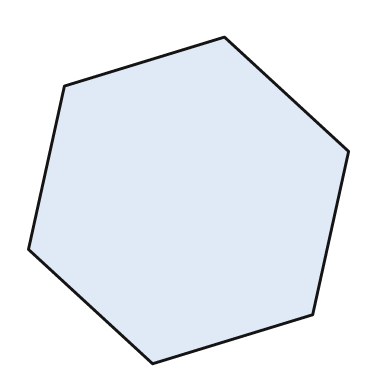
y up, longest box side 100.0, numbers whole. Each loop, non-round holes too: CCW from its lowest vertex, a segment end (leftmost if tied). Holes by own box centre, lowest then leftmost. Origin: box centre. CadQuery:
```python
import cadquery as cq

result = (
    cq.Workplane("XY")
    .moveTo(-11.0, -50.0)
    .lineTo(38.0, -35.0)
    .lineTo(49.0, 15.0)
    .lineTo(11.0, 50.0)
    .lineTo(-38.0, 35.0)
    .lineTo(-49.0, -15.0)
    .close()
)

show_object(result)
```